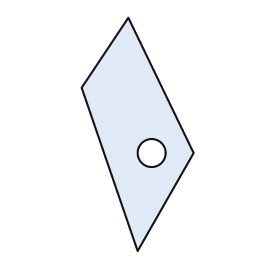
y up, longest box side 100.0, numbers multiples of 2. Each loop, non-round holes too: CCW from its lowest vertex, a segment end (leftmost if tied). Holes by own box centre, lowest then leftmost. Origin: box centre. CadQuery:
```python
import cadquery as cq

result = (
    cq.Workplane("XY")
    .moveTo(0.0, -50.0)
    .lineTo(24.0, -8.0)
    .lineTo(-4.0, 50.0)
    .lineTo(-24.0, 20.0)
    .close()
    .moveTo(6.0, -8.0)
    .circle(6.0)
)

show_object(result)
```